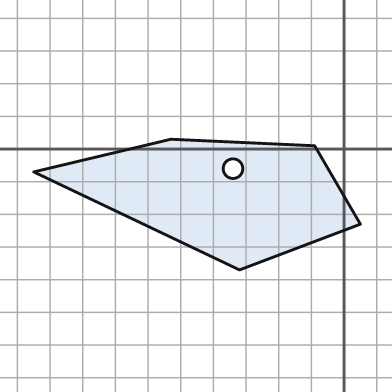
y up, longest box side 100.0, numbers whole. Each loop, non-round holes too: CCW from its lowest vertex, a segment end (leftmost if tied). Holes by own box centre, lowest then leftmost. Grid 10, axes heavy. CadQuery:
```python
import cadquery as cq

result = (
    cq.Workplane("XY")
    .moveTo(-32.0, -37.0)
    .lineTo(5.0, -23.0)
    .lineTo(-9.0, 1.0)
    .lineTo(-53.0, 3.0)
    .lineTo(-95.0, -7.0)
    .close()
    .moveTo(-34.0, -6.0)
    .circle(3.0)
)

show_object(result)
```